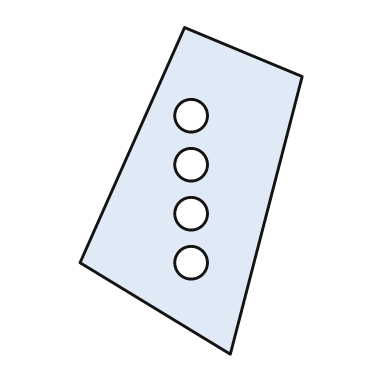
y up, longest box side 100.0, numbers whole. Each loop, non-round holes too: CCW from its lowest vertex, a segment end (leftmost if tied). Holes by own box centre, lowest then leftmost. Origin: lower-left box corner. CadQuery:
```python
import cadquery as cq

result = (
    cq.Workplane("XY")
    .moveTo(46.0, 0.0)
    .lineTo(68.0, 85.0)
    .lineTo(32.0, 100.0)
    .lineTo(0.0, 28.0)
    .close()
    .moveTo(34.0, 28.0)
    .circle(5.0)
    .moveTo(34.0, 43.0)
    .circle(5.0)
    .moveTo(34.0, 58.0)
    .circle(5.0)
    .moveTo(34.0, 73.0)
    .circle(5.0)
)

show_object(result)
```